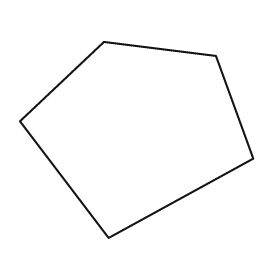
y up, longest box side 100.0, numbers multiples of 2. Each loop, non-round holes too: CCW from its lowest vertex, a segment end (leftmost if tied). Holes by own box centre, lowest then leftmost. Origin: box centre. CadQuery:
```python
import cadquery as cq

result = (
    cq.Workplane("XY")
    .moveTo(-12.0, -42.0)
    .lineTo(50.0, -8.0)
    .lineTo(34.0, 36.0)
    .lineTo(-14.0, 42.0)
    .lineTo(-50.0, 8.0)
    .close()
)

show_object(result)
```